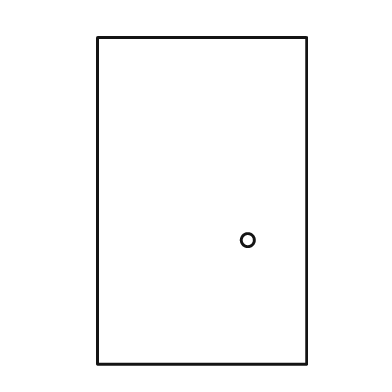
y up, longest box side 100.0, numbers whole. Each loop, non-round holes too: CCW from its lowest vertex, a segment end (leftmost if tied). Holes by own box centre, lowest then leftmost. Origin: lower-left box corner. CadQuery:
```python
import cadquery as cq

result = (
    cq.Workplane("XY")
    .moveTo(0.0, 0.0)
    .lineTo(64.0, 0.0)
    .lineTo(64.0, 100.0)
    .lineTo(0.0, 100.0)
    .close()
    .moveTo(46.0, 38.0)
    .circle(2.0)
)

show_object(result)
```